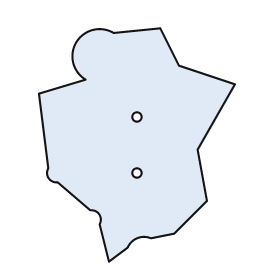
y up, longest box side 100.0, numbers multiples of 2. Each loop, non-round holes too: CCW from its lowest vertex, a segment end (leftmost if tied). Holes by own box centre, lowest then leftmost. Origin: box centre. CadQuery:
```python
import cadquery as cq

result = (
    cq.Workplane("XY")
    .moveTo(-12.0, -50.0)
    .lineTo(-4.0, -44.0)
    .threePointArc((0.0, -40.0), (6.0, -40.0))
    .lineTo(16.0, -38.0)
    .lineTo(30.0, -24.0)
    .lineTo(26.0, -2.0)
    .lineTo(42.0, 26.0)
    .lineTo(18.0, 34.0)
    .lineTo(10.0, 50.0)
    .lineTo(-10.0, 48.0)
    .threePointArc((-26.0, 44.0), (-22.0, 28.0))
    .lineTo(-42.0, 22.0)
    .lineTo(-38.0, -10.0)
    .threePointArc((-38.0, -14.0), (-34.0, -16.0))
    .lineTo(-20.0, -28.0)
    .threePointArc((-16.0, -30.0), (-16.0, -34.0))
    .close()
    .moveTo(0.0, -12.0)
    .circle(2.0)
    .moveTo(0.0, 12.0)
    .circle(2.0)
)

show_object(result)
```